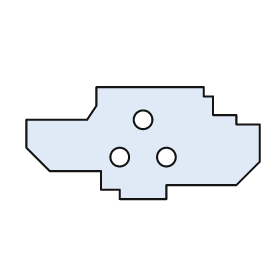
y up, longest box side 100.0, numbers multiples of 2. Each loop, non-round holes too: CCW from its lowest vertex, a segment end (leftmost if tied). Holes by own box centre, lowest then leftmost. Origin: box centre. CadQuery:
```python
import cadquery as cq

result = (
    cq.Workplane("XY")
    .moveTo(-10.0, -24.0)
    .lineTo(10.0, -24.0)
    .lineTo(10.0, -18.0)
    .lineTo(40.0, -18.0)
    .lineTo(50.0, -8.0)
    .lineTo(50.0, 8.0)
    .lineTo(40.0, 8.0)
    .lineTo(40.0, 12.0)
    .lineTo(30.0, 12.0)
    .lineTo(30.0, 20.0)
    .lineTo(26.0, 20.0)
    .lineTo(26.0, 24.0)
    .lineTo(-20.0, 24.0)
    .lineTo(-20.0, 16.0)
    .lineTo(-24.0, 10.0)
    .lineTo(-50.0, 10.0)
    .lineTo(-50.0, -2.0)
    .lineTo(-40.0, -12.0)
    .lineTo(-18.0, -12.0)
    .lineTo(-18.0, -20.0)
    .lineTo(-10.0, -20.0)
    .close()
    .moveTo(-10.0, -6.0)
    .circle(4.0)
    .moveTo(10.0, -6.0)
    .circle(4.0)
    .moveTo(0.0, 10.0)
    .circle(4.0)
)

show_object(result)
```